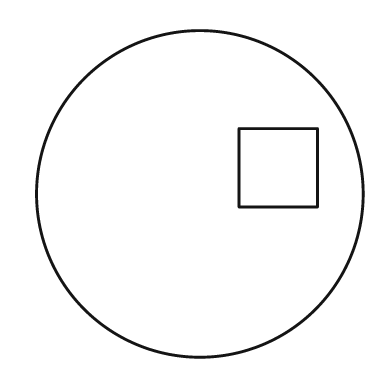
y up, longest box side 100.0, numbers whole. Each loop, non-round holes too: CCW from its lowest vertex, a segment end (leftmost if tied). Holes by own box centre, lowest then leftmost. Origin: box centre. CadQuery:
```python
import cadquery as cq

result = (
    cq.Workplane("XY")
    .moveTo(0.0, 0.0)
    .circle(50.0)
    .moveTo(12.0, -4.0)
    .lineTo(36.0, -4.0)
    .lineTo(36.0, 20.0)
    .lineTo(12.0, 20.0)
    .close()
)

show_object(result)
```